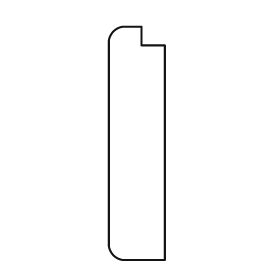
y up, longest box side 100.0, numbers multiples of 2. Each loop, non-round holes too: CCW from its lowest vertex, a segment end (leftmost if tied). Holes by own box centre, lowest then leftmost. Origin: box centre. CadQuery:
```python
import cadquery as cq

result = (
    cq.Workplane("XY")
    .moveTo(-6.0, -50.0)
    .lineTo(12.0, -50.0)
    .lineTo(12.0, 42.0)
    .lineTo(2.0, 42.0)
    .lineTo(2.0, 50.0)
    .lineTo(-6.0, 50.0)
    .threePointArc((-10.0, 48.0), (-12.0, 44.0))
    .lineTo(-12.0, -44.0)
    .threePointArc((-10.0, -48.0), (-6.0, -50.0))
    .close()
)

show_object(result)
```